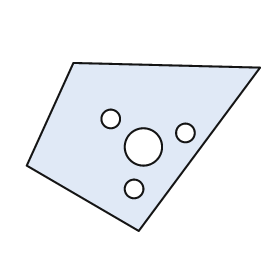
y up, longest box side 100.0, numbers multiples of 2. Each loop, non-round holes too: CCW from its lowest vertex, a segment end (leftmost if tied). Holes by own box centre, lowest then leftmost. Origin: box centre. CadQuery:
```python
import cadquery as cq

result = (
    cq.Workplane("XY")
    .moveTo(-2.0, -36.0)
    .lineTo(50.0, 34.0)
    .lineTo(-30.0, 36.0)
    .lineTo(-50.0, -8.0)
    .close()
    .moveTo(-4.0, -18.0)
    .circle(4.0)
    .moveTo(0.0, 0.0)
    .circle(8.0)
    .moveTo(18.0, 6.0)
    .circle(4.0)
    .moveTo(-14.0, 12.0)
    .circle(4.0)
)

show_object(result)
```